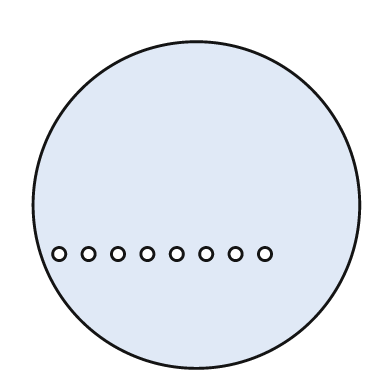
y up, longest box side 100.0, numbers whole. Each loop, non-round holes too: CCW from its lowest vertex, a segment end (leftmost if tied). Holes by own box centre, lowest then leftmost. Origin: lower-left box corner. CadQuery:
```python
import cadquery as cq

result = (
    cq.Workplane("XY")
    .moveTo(50.0, 50.0)
    .circle(50.0)
    .moveTo(8.0, 35.0)
    .circle(2.0)
    .moveTo(17.0, 35.0)
    .circle(2.0)
    .moveTo(26.0, 35.0)
    .circle(2.0)
    .moveTo(35.0, 35.0)
    .circle(2.0)
    .moveTo(44.0, 35.0)
    .circle(2.0)
    .moveTo(53.0, 35.0)
    .circle(2.0)
    .moveTo(62.0, 35.0)
    .circle(2.0)
    .moveTo(71.0, 35.0)
    .circle(2.0)
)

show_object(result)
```